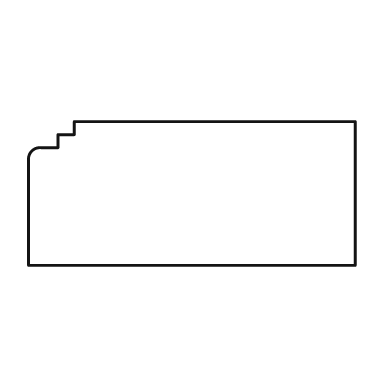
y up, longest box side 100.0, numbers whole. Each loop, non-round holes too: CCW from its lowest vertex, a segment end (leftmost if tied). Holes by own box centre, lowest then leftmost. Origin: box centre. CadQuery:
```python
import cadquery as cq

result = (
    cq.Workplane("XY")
    .moveTo(-50.0, -22.0)
    .lineTo(50.0, -22.0)
    .lineTo(50.0, 22.0)
    .lineTo(-36.0, 22.0)
    .lineTo(-36.0, 18.0)
    .lineTo(-41.0, 18.0)
    .lineTo(-41.0, 14.0)
    .lineTo(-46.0, 14.0)
    .threePointArc((-49.0, 13.0), (-50.0, 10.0))
    .close()
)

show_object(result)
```